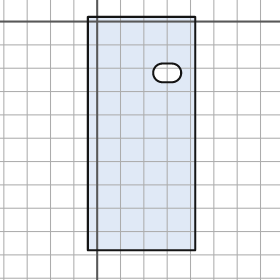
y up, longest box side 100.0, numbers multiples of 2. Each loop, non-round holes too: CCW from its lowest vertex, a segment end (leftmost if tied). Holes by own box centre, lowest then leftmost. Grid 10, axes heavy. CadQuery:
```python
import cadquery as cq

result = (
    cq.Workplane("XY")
    .moveTo(-4.0, -98.0)
    .lineTo(42.0, -98.0)
    .lineTo(42.0, 2.0)
    .lineTo(-4.0, 2.0)
    .close()
    .moveTo(28.0, -26.0)
    .lineTo(32.0, -26.0)
    .threePointArc((36.0, -22.0), (32.0, -18.0))
    .lineTo(28.0, -18.0)
    .threePointArc((24.0, -22.0), (28.0, -26.0))
    .close()
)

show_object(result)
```